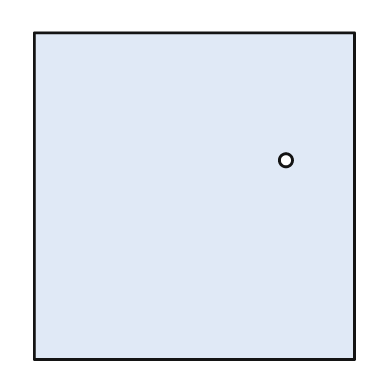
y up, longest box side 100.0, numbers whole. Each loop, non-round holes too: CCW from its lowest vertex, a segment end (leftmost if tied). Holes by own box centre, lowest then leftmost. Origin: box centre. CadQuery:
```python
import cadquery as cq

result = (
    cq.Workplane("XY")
    .moveTo(-49.0, -50.0)
    .lineTo(49.0, -50.0)
    .lineTo(49.0, 50.0)
    .lineTo(-49.0, 50.0)
    .close()
    .moveTo(28.0, 11.0)
    .circle(2.0)
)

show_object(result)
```